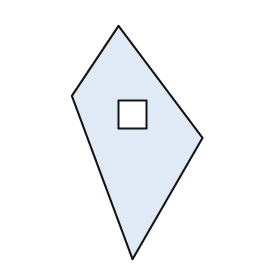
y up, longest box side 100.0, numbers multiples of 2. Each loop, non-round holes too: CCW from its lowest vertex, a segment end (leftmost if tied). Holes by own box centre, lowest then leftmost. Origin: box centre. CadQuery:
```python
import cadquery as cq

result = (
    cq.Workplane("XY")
    .moveTo(-2.0, -50.0)
    .lineTo(28.0, 2.0)
    .lineTo(-8.0, 50.0)
    .lineTo(-28.0, 20.0)
    .close()
    .moveTo(-8.0, 6.0)
    .lineTo(4.0, 6.0)
    .lineTo(4.0, 18.0)
    .lineTo(-8.0, 18.0)
    .close()
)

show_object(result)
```